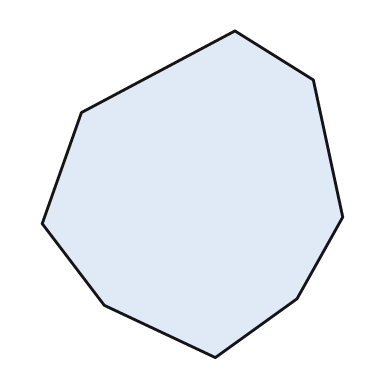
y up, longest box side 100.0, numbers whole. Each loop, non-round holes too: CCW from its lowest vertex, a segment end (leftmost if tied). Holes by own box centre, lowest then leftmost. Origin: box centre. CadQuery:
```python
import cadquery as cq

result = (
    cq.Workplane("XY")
    .moveTo(7.0, -50.0)
    .lineTo(32.0, -32.0)
    .lineTo(46.0, -7.0)
    .lineTo(37.0, 35.0)
    .lineTo(13.0, 50.0)
    .lineTo(-34.0, 25.0)
    .lineTo(-46.0, -9.0)
    .lineTo(-27.0, -34.0)
    .close()
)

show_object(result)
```